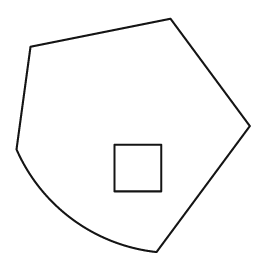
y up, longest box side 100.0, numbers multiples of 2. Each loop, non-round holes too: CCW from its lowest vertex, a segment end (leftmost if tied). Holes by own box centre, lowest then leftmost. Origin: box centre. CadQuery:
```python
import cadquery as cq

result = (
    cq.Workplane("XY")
    .moveTo(10.0, -50.0)
    .lineTo(50.0, 4.0)
    .lineTo(16.0, 50.0)
    .lineTo(-44.0, 38.0)
    .lineTo(-50.0, -6.0)
    .threePointArc((-26.0, -36.0), (10.0, -50.0))
    .close()
    .moveTo(-8.0, -24.0)
    .lineTo(12.0, -24.0)
    .lineTo(12.0, -4.0)
    .lineTo(-8.0, -4.0)
    .close()
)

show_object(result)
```